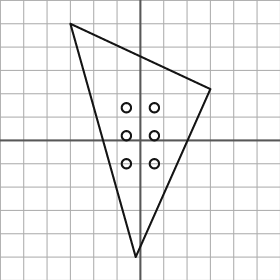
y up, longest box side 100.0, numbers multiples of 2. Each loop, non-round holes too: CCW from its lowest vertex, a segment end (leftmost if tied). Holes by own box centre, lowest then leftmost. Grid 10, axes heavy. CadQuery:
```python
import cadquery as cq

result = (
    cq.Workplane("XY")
    .moveTo(-2.0, -50.0)
    .lineTo(30.0, 22.0)
    .lineTo(-30.0, 50.0)
    .close()
    .moveTo(-6.0, -10.0)
    .circle(2.0)
    .moveTo(6.0, -10.0)
    .circle(2.0)
    .moveTo(-6.0, 2.0)
    .circle(2.0)
    .moveTo(6.0, 2.0)
    .circle(2.0)
    .moveTo(-6.0, 14.0)
    .circle(2.0)
    .moveTo(6.0, 14.0)
    .circle(2.0)
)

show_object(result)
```